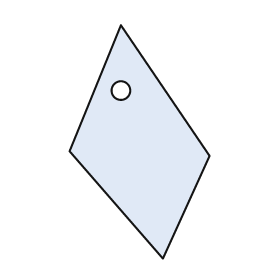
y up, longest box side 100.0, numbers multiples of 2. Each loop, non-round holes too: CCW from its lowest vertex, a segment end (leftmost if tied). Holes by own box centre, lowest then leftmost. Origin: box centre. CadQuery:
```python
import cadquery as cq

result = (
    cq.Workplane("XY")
    .moveTo(10.0, -50.0)
    .lineTo(30.0, -6.0)
    .lineTo(-8.0, 50.0)
    .lineTo(-30.0, -4.0)
    .close()
    .moveTo(-8.0, 22.0)
    .circle(4.0)
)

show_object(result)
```